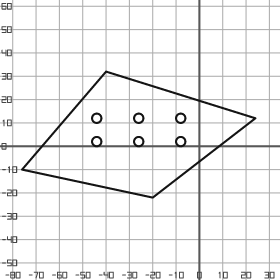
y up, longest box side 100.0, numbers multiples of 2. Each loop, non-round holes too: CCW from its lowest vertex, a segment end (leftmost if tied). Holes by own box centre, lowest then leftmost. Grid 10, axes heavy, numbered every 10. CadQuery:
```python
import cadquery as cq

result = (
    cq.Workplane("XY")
    .moveTo(-20.0, -22.0)
    .lineTo(24.0, 12.0)
    .lineTo(-40.0, 32.0)
    .lineTo(-76.0, -10.0)
    .close()
    .moveTo(-44.0, 2.0)
    .circle(2.0)
    .moveTo(-26.0, 2.0)
    .circle(2.0)
    .moveTo(-8.0, 2.0)
    .circle(2.0)
    .moveTo(-44.0, 12.0)
    .circle(2.0)
    .moveTo(-26.0, 12.0)
    .circle(2.0)
    .moveTo(-8.0, 12.0)
    .circle(2.0)
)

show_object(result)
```